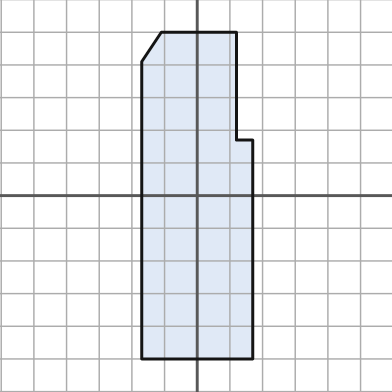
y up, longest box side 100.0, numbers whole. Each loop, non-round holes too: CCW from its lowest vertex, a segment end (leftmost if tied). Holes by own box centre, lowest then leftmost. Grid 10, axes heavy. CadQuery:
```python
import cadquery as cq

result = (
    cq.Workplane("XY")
    .moveTo(-17.0, -50.0)
    .lineTo(17.0, -50.0)
    .lineTo(17.0, 17.0)
    .lineTo(12.0, 17.0)
    .lineTo(12.0, 50.0)
    .lineTo(-11.0, 50.0)
    .lineTo(-17.0, 41.0)
    .close()
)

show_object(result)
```